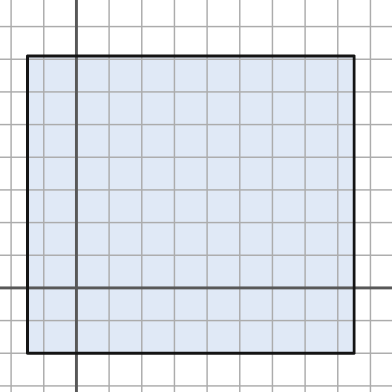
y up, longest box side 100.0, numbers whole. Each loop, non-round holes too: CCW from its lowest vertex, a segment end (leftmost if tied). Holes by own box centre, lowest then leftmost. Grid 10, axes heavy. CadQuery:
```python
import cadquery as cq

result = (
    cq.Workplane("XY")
    .moveTo(-15.0, -20.0)
    .lineTo(85.0, -20.0)
    .lineTo(85.0, 71.0)
    .lineTo(-15.0, 71.0)
    .close()
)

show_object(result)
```